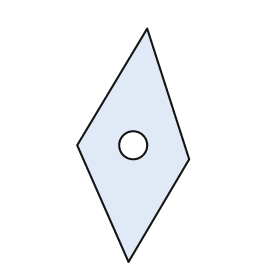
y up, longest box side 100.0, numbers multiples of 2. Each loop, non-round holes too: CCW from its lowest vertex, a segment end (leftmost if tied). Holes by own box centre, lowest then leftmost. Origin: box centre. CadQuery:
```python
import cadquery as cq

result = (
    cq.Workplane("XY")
    .moveTo(-2.0, -50.0)
    .lineTo(24.0, -6.0)
    .lineTo(6.0, 50.0)
    .lineTo(-24.0, 0.0)
    .close()
    .moveTo(0.0, 0.0)
    .circle(6.0)
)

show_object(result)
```